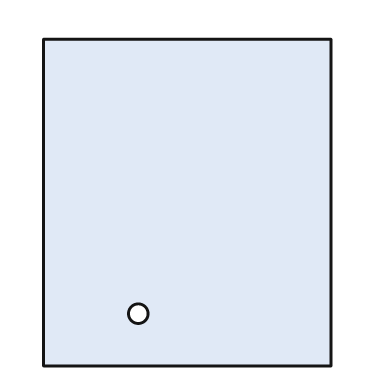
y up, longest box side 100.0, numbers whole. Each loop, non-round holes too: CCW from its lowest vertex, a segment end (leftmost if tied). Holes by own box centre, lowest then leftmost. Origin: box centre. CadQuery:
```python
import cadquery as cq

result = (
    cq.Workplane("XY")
    .moveTo(-44.0, -50.0)
    .lineTo(44.0, -50.0)
    .lineTo(44.0, 50.0)
    .lineTo(-44.0, 50.0)
    .close()
    .moveTo(-15.0, -34.0)
    .circle(3.0)
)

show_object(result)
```